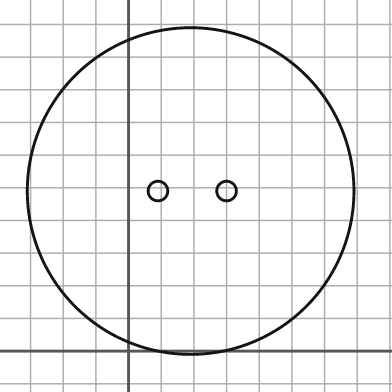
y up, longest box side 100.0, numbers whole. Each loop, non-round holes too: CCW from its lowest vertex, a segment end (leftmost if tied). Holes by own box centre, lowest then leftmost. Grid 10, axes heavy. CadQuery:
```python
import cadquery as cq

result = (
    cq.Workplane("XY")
    .moveTo(19.0, 49.0)
    .circle(50.0)
    .moveTo(9.0, 49.0)
    .circle(3.0)
    .moveTo(30.0, 49.0)
    .circle(3.0)
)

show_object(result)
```